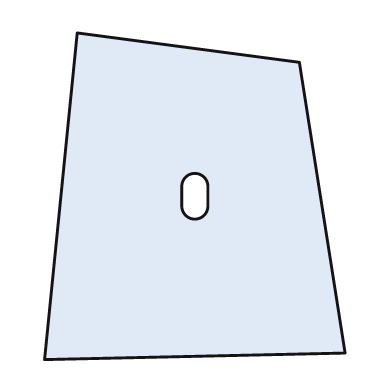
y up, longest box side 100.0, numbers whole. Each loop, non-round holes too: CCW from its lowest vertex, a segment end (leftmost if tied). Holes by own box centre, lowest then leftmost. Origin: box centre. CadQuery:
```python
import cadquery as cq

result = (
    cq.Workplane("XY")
    .moveTo(-46.0, -50.0)
    .lineTo(46.0, -48.0)
    .lineTo(32.0, 41.0)
    .lineTo(-36.0, 50.0)
    .close()
    .moveTo(-4.0, -3.0)
    .threePointArc((0.0, -7.0), (4.0, -3.0))
    .lineTo(4.0, 3.0)
    .threePointArc((0.0, 7.0), (-4.0, 3.0))
    .close()
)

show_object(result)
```